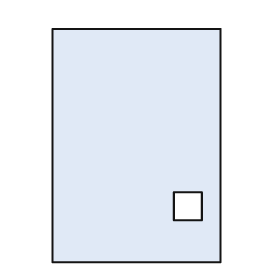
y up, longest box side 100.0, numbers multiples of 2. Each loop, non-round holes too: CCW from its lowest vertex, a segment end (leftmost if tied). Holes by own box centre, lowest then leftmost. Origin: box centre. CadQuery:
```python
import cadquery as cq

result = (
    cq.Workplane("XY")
    .moveTo(-36.0, -50.0)
    .lineTo(36.0, -50.0)
    .lineTo(36.0, 50.0)
    .lineTo(-36.0, 50.0)
    .close()
    .moveTo(16.0, -32.0)
    .lineTo(28.0, -32.0)
    .lineTo(28.0, -20.0)
    .lineTo(16.0, -20.0)
    .close()
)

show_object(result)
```